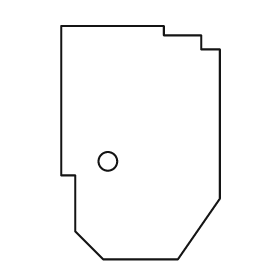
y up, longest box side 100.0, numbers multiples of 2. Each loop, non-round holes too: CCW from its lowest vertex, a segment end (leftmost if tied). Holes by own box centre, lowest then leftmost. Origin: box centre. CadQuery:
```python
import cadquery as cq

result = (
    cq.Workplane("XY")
    .moveTo(-16.0, -50.0)
    .lineTo(16.0, -50.0)
    .lineTo(34.0, -24.0)
    .lineTo(34.0, 40.0)
    .lineTo(26.0, 40.0)
    .lineTo(26.0, 46.0)
    .lineTo(10.0, 46.0)
    .lineTo(10.0, 50.0)
    .lineTo(-34.0, 50.0)
    .lineTo(-34.0, -14.0)
    .lineTo(-28.0, -14.0)
    .lineTo(-28.0, -38.0)
    .close()
    .moveTo(-14.0, -8.0)
    .circle(4.0)
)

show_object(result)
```